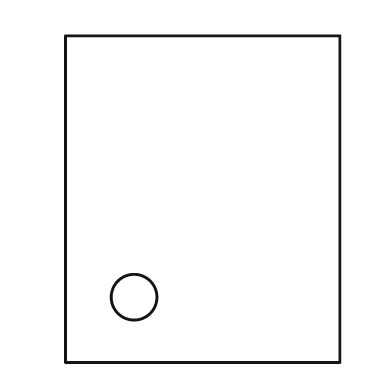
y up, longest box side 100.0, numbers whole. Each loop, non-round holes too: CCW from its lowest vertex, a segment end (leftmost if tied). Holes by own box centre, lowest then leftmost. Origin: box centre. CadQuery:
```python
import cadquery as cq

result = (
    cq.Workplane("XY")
    .moveTo(-42.0, -50.0)
    .lineTo(42.0, -50.0)
    .lineTo(42.0, 50.0)
    .lineTo(-42.0, 50.0)
    .close()
    .moveTo(-21.0, -30.0)
    .circle(7.0)
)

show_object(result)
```